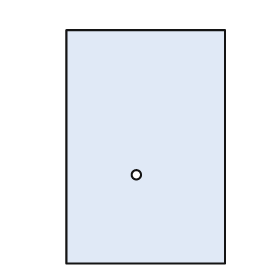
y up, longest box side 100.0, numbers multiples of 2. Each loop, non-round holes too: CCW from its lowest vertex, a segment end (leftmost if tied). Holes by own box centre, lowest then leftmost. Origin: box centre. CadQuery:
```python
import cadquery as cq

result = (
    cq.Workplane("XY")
    .moveTo(-34.0, -50.0)
    .lineTo(34.0, -50.0)
    .lineTo(34.0, 50.0)
    .lineTo(-34.0, 50.0)
    .close()
    .moveTo(-4.0, -12.0)
    .circle(2.0)
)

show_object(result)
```